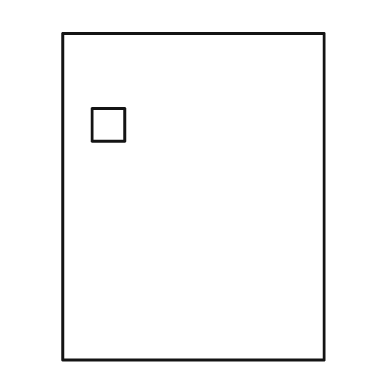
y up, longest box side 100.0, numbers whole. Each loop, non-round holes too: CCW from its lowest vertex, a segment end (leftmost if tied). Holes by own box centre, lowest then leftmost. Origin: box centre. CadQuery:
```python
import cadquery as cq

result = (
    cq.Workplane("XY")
    .moveTo(-40.0, -50.0)
    .lineTo(40.0, -50.0)
    .lineTo(40.0, 50.0)
    .lineTo(-40.0, 50.0)
    .close()
    .moveTo(-31.0, 17.0)
    .lineTo(-21.0, 17.0)
    .lineTo(-21.0, 27.0)
    .lineTo(-31.0, 27.0)
    .close()
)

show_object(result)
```